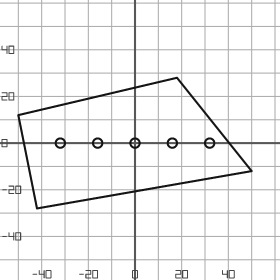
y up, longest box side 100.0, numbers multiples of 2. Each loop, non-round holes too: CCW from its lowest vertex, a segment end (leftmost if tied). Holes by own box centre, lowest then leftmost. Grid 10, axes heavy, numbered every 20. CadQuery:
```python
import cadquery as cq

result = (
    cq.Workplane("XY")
    .moveTo(-42.0, -28.0)
    .lineTo(50.0, -12.0)
    .lineTo(18.0, 28.0)
    .lineTo(-50.0, 12.0)
    .close()
    .moveTo(-32.0, 0.0)
    .circle(2.0)
    .moveTo(-16.0, 0.0)
    .circle(2.0)
    .moveTo(0.0, 0.0)
    .circle(2.0)
    .moveTo(16.0, 0.0)
    .circle(2.0)
    .moveTo(32.0, 0.0)
    .circle(2.0)
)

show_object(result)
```